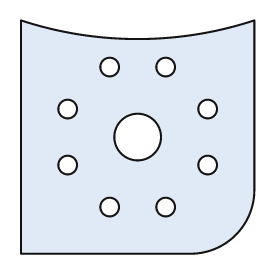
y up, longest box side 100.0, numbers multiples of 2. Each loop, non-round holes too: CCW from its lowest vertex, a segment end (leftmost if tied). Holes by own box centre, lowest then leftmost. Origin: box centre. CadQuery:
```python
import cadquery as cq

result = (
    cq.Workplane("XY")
    .moveTo(-50.0, -50.0)
    .lineTo(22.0, -50.0)
    .threePointArc((42.0, -42.0), (50.0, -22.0))
    .lineTo(50.0, 50.0)
    .threePointArc((0.0, 42.0), (-50.0, 50.0))
    .close()
    .moveTo(-12.0, -30.0)
    .circle(4.0)
    .moveTo(12.0, -30.0)
    .circle(4.0)
    .moveTo(-30.0, -12.0)
    .circle(4.0)
    .moveTo(30.0, -12.0)
    .circle(4.0)
    .moveTo(0.0, 0.0)
    .circle(10.0)
    .moveTo(-30.0, 12.0)
    .circle(4.0)
    .moveTo(30.0, 12.0)
    .circle(4.0)
    .moveTo(-12.0, 30.0)
    .circle(4.0)
    .moveTo(12.0, 30.0)
    .circle(4.0)
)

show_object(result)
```